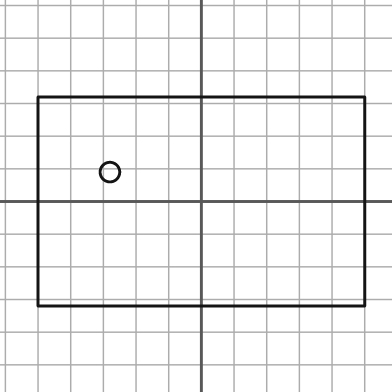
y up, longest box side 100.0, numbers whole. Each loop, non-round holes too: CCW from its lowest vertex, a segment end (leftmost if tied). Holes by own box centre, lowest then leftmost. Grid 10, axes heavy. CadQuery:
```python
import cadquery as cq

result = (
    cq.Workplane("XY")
    .moveTo(-50.0, -32.0)
    .lineTo(50.0, -32.0)
    .lineTo(50.0, 32.0)
    .lineTo(-50.0, 32.0)
    .close()
    .moveTo(-28.0, 9.0)
    .circle(3.0)
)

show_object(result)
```